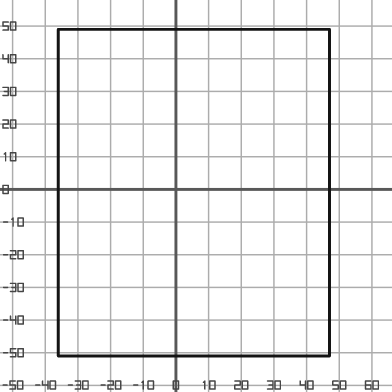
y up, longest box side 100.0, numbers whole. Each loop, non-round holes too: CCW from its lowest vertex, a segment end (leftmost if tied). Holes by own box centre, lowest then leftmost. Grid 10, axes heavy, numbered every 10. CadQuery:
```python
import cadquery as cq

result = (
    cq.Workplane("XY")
    .moveTo(-36.0, -51.0)
    .lineTo(47.0, -51.0)
    .lineTo(47.0, 49.0)
    .lineTo(-36.0, 49.0)
    .close()
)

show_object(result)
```